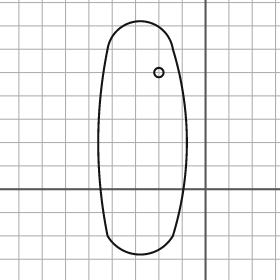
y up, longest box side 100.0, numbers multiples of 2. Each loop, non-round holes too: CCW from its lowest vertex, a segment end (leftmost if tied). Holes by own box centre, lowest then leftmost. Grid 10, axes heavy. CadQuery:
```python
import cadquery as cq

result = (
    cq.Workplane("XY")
    .moveTo(-42.0, -20.0)
    .threePointArc((-28.0, -28.0), (-14.0, -20.0))
    .threePointArc((-8.0, 20.0), (-14.0, 60.0))
    .threePointArc((-28.0, 72.0), (-42.0, 60.0))
    .threePointArc((-46.0, 20.0), (-42.0, -20.0))
    .close()
    .moveTo(-20.0, 50.0)
    .circle(2.0)
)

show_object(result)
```